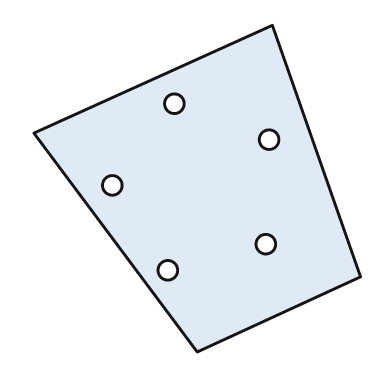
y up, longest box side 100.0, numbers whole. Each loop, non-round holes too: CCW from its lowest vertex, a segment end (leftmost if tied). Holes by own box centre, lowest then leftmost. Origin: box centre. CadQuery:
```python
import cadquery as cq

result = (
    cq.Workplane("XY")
    .moveTo(0.0, -50.0)
    .lineTo(50.0, -27.0)
    .lineTo(23.0, 50.0)
    .lineTo(-50.0, 17.0)
    .close()
    .moveTo(-9.0, -25.0)
    .circle(3.0)
    .moveTo(21.0, -17.0)
    .circle(3.0)
    .moveTo(-26.0, 1.0)
    .circle(3.0)
    .moveTo(22.0, 15.0)
    .circle(3.0)
    .moveTo(-7.0, 26.0)
    .circle(3.0)
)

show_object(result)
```